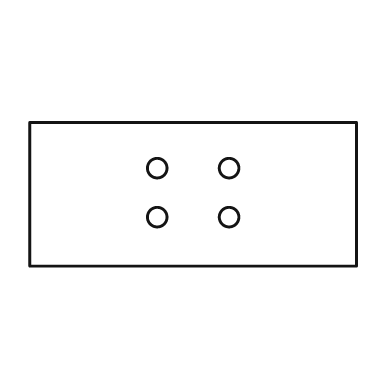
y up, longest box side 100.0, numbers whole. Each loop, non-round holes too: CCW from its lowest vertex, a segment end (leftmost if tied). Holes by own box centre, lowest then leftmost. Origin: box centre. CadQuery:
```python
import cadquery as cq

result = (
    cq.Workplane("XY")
    .moveTo(-50.0, -22.0)
    .lineTo(50.0, -22.0)
    .lineTo(50.0, 22.0)
    .lineTo(-50.0, 22.0)
    .close()
    .moveTo(-11.0, -7.0)
    .circle(3.0)
    .moveTo(11.0, -7.0)
    .circle(3.0)
    .moveTo(-11.0, 8.0)
    .circle(3.0)
    .moveTo(11.0, 8.0)
    .circle(3.0)
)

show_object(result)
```